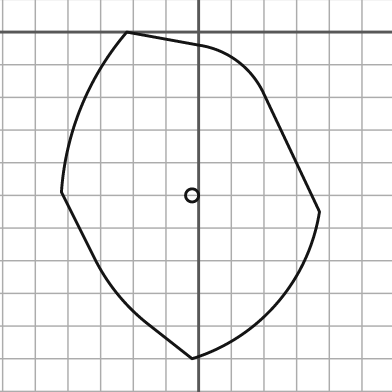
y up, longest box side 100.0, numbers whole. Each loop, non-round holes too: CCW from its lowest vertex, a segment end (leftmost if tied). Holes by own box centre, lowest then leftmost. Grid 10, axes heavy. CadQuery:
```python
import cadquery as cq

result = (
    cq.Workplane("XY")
    .moveTo(-2.0, -100.0)
    .threePointArc((24.0, -83.0), (37.0, -55.0))
    .lineTo(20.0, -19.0)
    .threePointArc((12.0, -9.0), (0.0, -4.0))
    .lineTo(-22.0, 0.0)
    .threePointArc((-36.0, -23.0), (-42.0, -49.0))
    .lineTo(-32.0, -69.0)
    .threePointArc((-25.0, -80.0), (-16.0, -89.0))
    .close()
    .moveTo(-2.0, -50.0)
    .circle(2.0)
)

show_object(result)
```